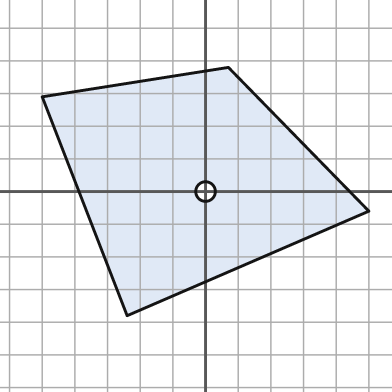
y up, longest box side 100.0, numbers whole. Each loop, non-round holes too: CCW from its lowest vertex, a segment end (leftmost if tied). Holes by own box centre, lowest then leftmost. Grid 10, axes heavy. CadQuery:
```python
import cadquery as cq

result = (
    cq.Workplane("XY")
    .moveTo(-24.0, -38.0)
    .lineTo(50.0, -6.0)
    .lineTo(7.0, 38.0)
    .lineTo(-50.0, 29.0)
    .close()
    .moveTo(0.0, 0.0)
    .circle(3.0)
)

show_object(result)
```